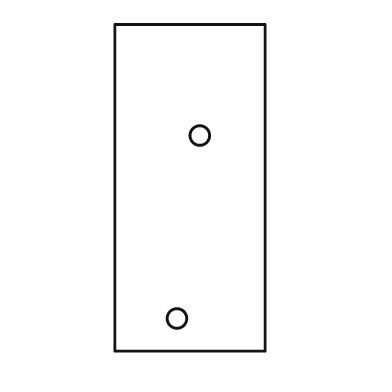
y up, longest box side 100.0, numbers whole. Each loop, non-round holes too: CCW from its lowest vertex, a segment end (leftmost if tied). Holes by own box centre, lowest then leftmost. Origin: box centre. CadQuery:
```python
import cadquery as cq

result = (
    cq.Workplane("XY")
    .moveTo(-23.0, -50.0)
    .lineTo(23.0, -50.0)
    .lineTo(23.0, 50.0)
    .lineTo(-23.0, 50.0)
    .close()
    .moveTo(-4.0, -40.0)
    .circle(3.0)
    .moveTo(3.0, 16.0)
    .circle(3.0)
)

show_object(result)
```